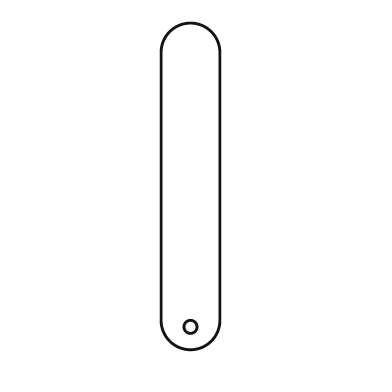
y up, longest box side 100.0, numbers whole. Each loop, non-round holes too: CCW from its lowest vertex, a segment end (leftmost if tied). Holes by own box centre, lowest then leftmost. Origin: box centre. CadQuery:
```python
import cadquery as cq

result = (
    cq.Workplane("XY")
    .moveTo(-9.0, -41.0)
    .threePointArc((0.0, -50.0), (9.0, -41.0))
    .lineTo(9.0, 41.0)
    .threePointArc((0.0, 50.0), (-9.0, 41.0))
    .close()
    .moveTo(0.0, -43.0)
    .circle(2.0)
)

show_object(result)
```